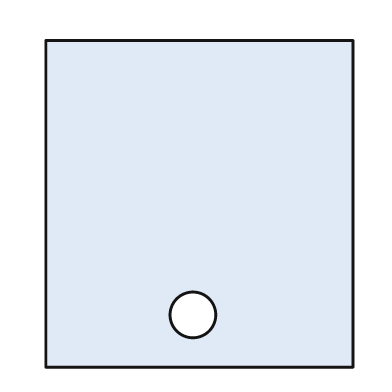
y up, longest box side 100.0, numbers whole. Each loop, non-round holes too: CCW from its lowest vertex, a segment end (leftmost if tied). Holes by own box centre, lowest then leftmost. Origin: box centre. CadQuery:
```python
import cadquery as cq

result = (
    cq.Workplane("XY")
    .moveTo(-47.0, -50.0)
    .lineTo(47.0, -50.0)
    .lineTo(47.0, 50.0)
    .lineTo(-47.0, 50.0)
    .close()
    .moveTo(-2.0, -34.0)
    .circle(7.0)
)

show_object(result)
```